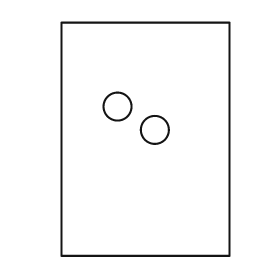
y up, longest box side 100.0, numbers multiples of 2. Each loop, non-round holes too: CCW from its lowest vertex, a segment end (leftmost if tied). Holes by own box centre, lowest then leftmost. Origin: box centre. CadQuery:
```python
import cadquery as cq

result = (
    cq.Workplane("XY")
    .moveTo(-36.0, -50.0)
    .lineTo(36.0, -50.0)
    .lineTo(36.0, 50.0)
    .lineTo(-36.0, 50.0)
    .close()
    .moveTo(4.0, 4.0)
    .circle(6.0)
    .moveTo(-12.0, 14.0)
    .circle(6.0)
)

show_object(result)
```